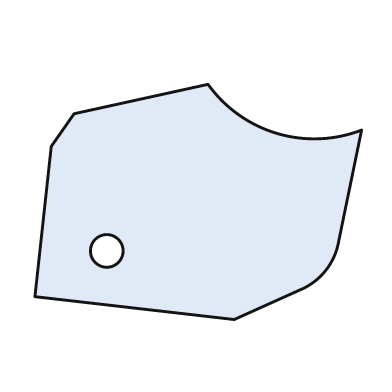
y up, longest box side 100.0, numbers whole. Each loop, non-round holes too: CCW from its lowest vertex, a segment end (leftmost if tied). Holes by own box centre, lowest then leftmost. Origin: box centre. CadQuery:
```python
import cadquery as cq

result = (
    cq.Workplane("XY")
    .moveTo(11.0, -36.0)
    .lineTo(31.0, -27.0)
    .threePointArc((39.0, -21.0), (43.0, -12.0))
    .lineTo(50.0, 22.0)
    .threePointArc((24.0, 21.0), (3.0, 36.0))
    .lineTo(-38.0, 27.0)
    .lineTo(-45.0, 17.0)
    .lineTo(-50.0, -29.0)
    .close()
    .moveTo(-28.0, -15.0)
    .circle(5.0)
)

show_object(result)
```